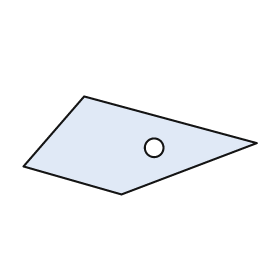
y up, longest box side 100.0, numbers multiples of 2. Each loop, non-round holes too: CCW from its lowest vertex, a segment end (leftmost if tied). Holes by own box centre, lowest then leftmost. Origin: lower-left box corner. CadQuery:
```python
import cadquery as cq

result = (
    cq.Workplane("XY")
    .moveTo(42.0, 0.0)
    .lineTo(100.0, 22.0)
    .lineTo(26.0, 42.0)
    .lineTo(0.0, 12.0)
    .close()
    .moveTo(56.0, 20.0)
    .circle(4.0)
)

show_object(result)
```